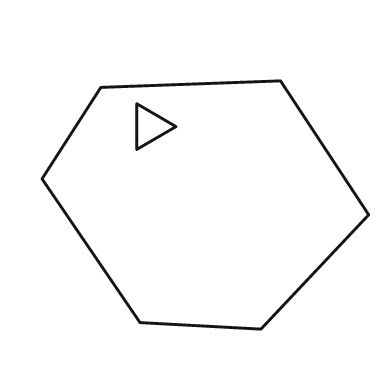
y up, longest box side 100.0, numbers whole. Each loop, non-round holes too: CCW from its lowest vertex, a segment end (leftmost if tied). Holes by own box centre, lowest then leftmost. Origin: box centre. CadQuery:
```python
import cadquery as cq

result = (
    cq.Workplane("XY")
    .moveTo(17.0, -38.0)
    .lineTo(50.0, -3.0)
    .lineTo(23.0, 38.0)
    .lineTo(-32.0, 36.0)
    .lineTo(-50.0, 8.0)
    .lineTo(-20.0, -36.0)
    .close()
    .moveTo(-21.0, 17.0)
    .lineTo(-9.0, 24.0)
    .lineTo(-21.0, 31.0)
    .close()
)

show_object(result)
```